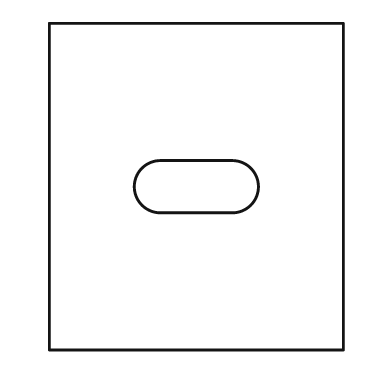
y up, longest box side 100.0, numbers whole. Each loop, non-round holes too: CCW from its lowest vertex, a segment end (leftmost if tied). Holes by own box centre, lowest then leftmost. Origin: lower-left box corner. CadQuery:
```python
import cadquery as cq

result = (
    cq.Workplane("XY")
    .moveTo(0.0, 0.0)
    .lineTo(90.0, 0.0)
    .lineTo(90.0, 100.0)
    .lineTo(0.0, 100.0)
    .close()
    .moveTo(34.0, 42.0)
    .lineTo(56.0, 42.0)
    .threePointArc((64.0, 50.0), (56.0, 58.0))
    .lineTo(34.0, 58.0)
    .threePointArc((26.0, 50.0), (34.0, 42.0))
    .close()
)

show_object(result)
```